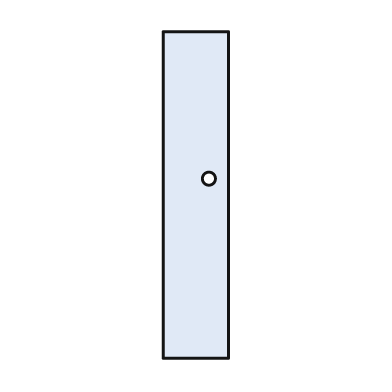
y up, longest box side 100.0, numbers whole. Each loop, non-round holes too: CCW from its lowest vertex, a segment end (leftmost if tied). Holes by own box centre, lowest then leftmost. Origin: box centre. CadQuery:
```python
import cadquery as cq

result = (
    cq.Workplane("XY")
    .moveTo(-10.0, -50.0)
    .lineTo(10.0, -50.0)
    .lineTo(10.0, 50.0)
    .lineTo(-10.0, 50.0)
    .close()
    .moveTo(4.0, 5.0)
    .circle(2.0)
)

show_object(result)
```